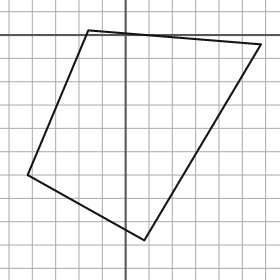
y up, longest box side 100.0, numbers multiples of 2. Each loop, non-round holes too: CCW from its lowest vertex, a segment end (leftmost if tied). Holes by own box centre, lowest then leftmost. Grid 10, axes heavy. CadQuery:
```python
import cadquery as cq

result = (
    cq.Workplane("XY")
    .moveTo(8.0, -88.0)
    .lineTo(58.0, -4.0)
    .lineTo(-16.0, 2.0)
    .lineTo(-42.0, -60.0)
    .close()
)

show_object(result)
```